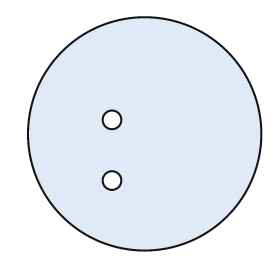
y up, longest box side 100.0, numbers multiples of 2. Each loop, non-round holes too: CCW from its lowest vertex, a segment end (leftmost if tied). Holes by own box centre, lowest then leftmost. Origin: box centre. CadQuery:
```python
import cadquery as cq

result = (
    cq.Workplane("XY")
    .moveTo(0.0, 0.0)
    .circle(50.0)
    .moveTo(-14.0, -20.0)
    .circle(4.0)
    .moveTo(-14.0, 6.0)
    .circle(4.0)
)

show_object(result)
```